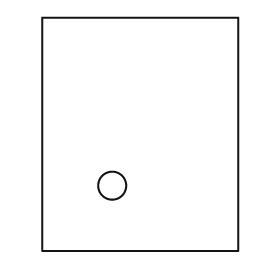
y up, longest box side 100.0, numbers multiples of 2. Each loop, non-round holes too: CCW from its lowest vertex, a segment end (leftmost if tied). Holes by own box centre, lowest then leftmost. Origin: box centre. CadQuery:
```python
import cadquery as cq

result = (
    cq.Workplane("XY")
    .moveTo(-42.0, -50.0)
    .lineTo(42.0, -50.0)
    .lineTo(42.0, 50.0)
    .lineTo(-42.0, 50.0)
    .close()
    .moveTo(-12.0, -22.0)
    .circle(6.0)
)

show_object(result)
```